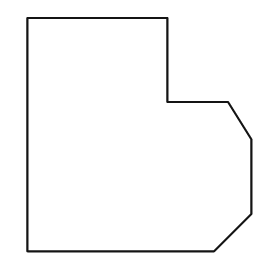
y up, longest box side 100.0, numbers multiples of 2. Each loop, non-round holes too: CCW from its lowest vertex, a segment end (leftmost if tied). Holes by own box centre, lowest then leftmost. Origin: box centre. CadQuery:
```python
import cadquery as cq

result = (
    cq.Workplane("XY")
    .moveTo(-48.0, -50.0)
    .lineTo(32.0, -50.0)
    .lineTo(48.0, -34.0)
    .lineTo(48.0, -2.0)
    .lineTo(38.0, 14.0)
    .lineTo(12.0, 14.0)
    .lineTo(12.0, 50.0)
    .lineTo(-48.0, 50.0)
    .close()
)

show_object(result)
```